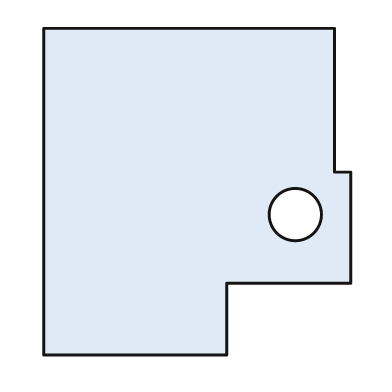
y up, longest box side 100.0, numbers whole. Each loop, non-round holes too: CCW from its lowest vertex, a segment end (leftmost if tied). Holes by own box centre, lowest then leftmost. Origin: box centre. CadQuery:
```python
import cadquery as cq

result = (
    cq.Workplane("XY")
    .moveTo(-47.0, -50.0)
    .lineTo(9.0, -50.0)
    .lineTo(9.0, -28.0)
    .lineTo(47.0, -28.0)
    .lineTo(47.0, 6.0)
    .lineTo(42.0, 6.0)
    .lineTo(42.0, 50.0)
    .lineTo(-47.0, 50.0)
    .close()
    .moveTo(30.0, -7.0)
    .circle(8.0)
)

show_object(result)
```